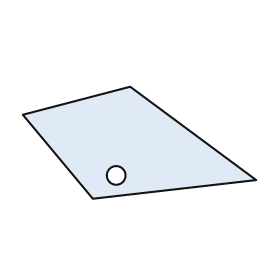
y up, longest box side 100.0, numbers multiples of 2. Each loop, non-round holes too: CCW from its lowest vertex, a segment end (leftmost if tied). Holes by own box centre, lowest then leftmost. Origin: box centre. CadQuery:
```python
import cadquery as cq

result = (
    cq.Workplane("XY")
    .moveTo(-20.0, -24.0)
    .lineTo(50.0, -16.0)
    .lineTo(-4.0, 24.0)
    .lineTo(-50.0, 12.0)
    .close()
    .moveTo(-10.0, -14.0)
    .circle(4.0)
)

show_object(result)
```